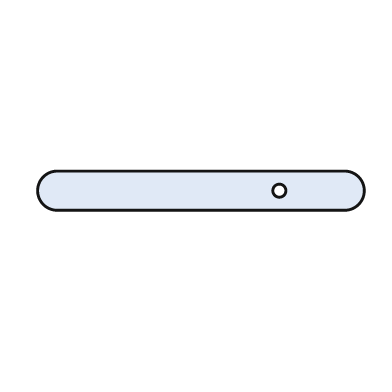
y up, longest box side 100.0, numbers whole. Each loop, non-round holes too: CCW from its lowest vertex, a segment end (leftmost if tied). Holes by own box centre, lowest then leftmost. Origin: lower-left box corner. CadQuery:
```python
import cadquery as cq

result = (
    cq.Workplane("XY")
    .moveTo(6.0, 0.0)
    .lineTo(94.0, 0.0)
    .threePointArc((100.0, 6.0), (94.0, 12.0))
    .lineTo(6.0, 12.0)
    .threePointArc((0.0, 6.0), (6.0, 0.0))
    .close()
    .moveTo(74.0, 6.0)
    .circle(2.0)
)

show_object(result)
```